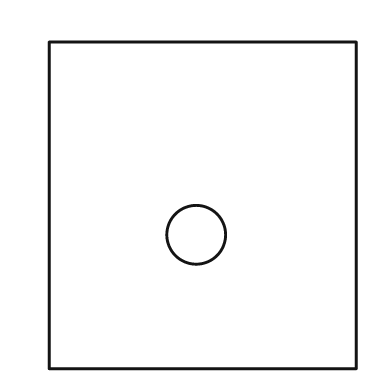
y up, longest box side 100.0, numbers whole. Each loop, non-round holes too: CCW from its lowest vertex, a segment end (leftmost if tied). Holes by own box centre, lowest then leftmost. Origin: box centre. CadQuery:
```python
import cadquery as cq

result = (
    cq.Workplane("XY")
    .moveTo(-47.0, -50.0)
    .lineTo(47.0, -50.0)
    .lineTo(47.0, 50.0)
    .lineTo(-47.0, 50.0)
    .close()
    .moveTo(-2.0, -9.0)
    .circle(9.0)
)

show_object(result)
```